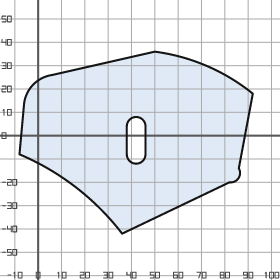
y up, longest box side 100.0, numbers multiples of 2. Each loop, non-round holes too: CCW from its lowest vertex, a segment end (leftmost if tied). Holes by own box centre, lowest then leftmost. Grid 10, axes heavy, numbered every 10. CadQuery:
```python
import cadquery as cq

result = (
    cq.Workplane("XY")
    .moveTo(36.0, -42.0)
    .lineTo(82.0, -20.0)
    .threePointArc((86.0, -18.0), (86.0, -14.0))
    .lineTo(92.0, 18.0)
    .threePointArc((72.0, 30.0), (50.0, 36.0))
    .lineTo(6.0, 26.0)
    .threePointArc((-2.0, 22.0), (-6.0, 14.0))
    .lineTo(-8.0, -8.0)
    .threePointArc((16.0, -22.0), (36.0, -42.0))
    .close()
    .moveTo(38.0, -8.0)
    .threePointArc((42.0, -12.0), (46.0, -8.0))
    .lineTo(46.0, 4.0)
    .threePointArc((42.0, 8.0), (38.0, 4.0))
    .close()
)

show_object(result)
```